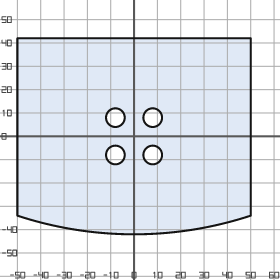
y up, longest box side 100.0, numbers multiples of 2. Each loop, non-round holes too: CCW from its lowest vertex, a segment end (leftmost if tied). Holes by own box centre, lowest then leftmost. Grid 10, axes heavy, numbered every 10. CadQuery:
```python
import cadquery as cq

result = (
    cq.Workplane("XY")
    .moveTo(-50.0, -34.0)
    .threePointArc((0.0, -42.0), (50.0, -34.0))
    .lineTo(50.0, 42.0)
    .lineTo(-50.0, 42.0)
    .close()
    .moveTo(-8.0, -8.0)
    .circle(4.0)
    .moveTo(8.0, -8.0)
    .circle(4.0)
    .moveTo(-8.0, 8.0)
    .circle(4.0)
    .moveTo(8.0, 8.0)
    .circle(4.0)
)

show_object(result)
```